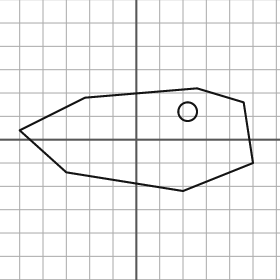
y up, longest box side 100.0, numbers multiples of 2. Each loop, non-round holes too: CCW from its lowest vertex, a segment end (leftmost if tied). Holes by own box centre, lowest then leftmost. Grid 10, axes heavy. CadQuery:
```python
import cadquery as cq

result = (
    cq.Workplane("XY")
    .moveTo(20.0, -22.0)
    .lineTo(50.0, -10.0)
    .lineTo(46.0, 16.0)
    .lineTo(26.0, 22.0)
    .lineTo(-22.0, 18.0)
    .lineTo(-50.0, 4.0)
    .lineTo(-30.0, -14.0)
    .close()
    .moveTo(22.0, 12.0)
    .circle(4.0)
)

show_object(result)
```